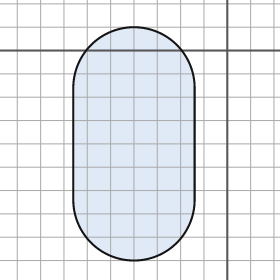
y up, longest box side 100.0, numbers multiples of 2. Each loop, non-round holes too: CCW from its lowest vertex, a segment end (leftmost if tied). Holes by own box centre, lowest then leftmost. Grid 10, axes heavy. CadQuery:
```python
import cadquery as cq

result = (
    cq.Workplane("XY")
    .moveTo(-66.0, -64.0)
    .threePointArc((-40.0, -90.0), (-14.0, -64.0))
    .lineTo(-14.0, -16.0)
    .threePointArc((-40.0, 10.0), (-66.0, -16.0))
    .close()
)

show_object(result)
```